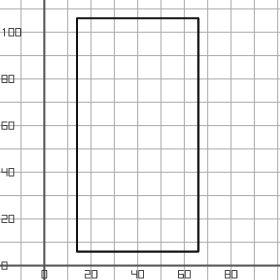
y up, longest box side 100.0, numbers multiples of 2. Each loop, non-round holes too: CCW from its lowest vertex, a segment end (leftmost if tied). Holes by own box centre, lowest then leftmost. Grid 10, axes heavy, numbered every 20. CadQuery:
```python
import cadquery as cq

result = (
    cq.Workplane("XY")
    .moveTo(14.0, 6.0)
    .lineTo(66.0, 6.0)
    .lineTo(66.0, 106.0)
    .lineTo(14.0, 106.0)
    .close()
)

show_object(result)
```